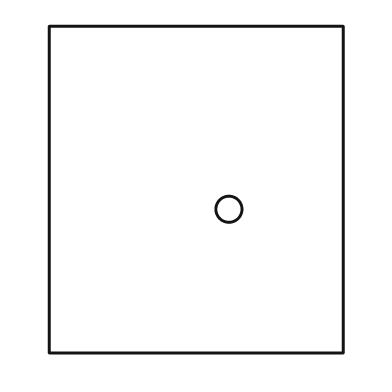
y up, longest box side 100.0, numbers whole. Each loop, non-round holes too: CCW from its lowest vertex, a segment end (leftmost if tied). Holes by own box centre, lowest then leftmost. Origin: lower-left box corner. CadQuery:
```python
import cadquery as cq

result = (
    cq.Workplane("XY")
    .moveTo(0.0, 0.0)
    .lineTo(90.0, 0.0)
    .lineTo(90.0, 100.0)
    .lineTo(0.0, 100.0)
    .close()
    .moveTo(55.0, 44.0)
    .circle(4.0)
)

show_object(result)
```